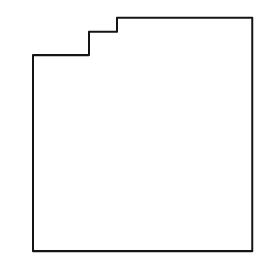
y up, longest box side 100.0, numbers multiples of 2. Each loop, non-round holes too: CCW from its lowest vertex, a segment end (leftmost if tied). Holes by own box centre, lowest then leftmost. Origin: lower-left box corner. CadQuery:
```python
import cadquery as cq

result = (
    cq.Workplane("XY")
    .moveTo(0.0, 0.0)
    .lineTo(94.0, 0.0)
    .lineTo(94.0, 100.0)
    .lineTo(36.0, 100.0)
    .lineTo(36.0, 94.0)
    .lineTo(24.0, 94.0)
    .lineTo(24.0, 84.0)
    .lineTo(0.0, 84.0)
    .close()
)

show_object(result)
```